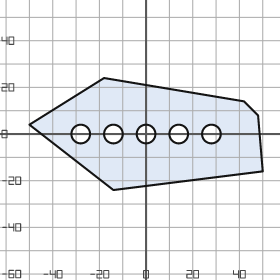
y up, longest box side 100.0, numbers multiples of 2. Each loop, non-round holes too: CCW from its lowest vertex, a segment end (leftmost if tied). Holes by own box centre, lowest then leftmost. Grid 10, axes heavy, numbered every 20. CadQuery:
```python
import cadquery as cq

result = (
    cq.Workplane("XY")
    .moveTo(-14.0, -24.0)
    .lineTo(50.0, -16.0)
    .lineTo(48.0, 8.0)
    .lineTo(42.0, 14.0)
    .lineTo(-18.0, 24.0)
    .lineTo(-50.0, 4.0)
    .close()
    .moveTo(-28.0, 0.0)
    .circle(4.0)
    .moveTo(-14.0, 0.0)
    .circle(4.0)
    .moveTo(0.0, 0.0)
    .circle(4.0)
    .moveTo(14.0, 0.0)
    .circle(4.0)
    .moveTo(28.0, 0.0)
    .circle(4.0)
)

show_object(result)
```